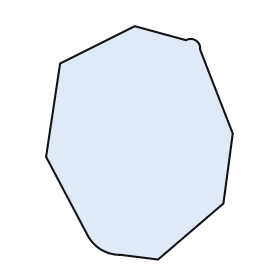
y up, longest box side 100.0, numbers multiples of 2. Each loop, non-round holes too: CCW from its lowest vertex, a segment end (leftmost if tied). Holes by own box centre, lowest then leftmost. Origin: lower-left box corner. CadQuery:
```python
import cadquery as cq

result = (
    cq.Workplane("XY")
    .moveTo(48.0, 0.0)
    .lineTo(76.0, 24.0)
    .lineTo(80.0, 54.0)
    .lineTo(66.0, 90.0)
    .threePointArc((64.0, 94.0), (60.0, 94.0))
    .lineTo(38.0, 100.0)
    .lineTo(6.0, 84.0)
    .lineTo(0.0, 44.0)
    .lineTo(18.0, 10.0)
    .threePointArc((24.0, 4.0), (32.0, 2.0))
    .close()
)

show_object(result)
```